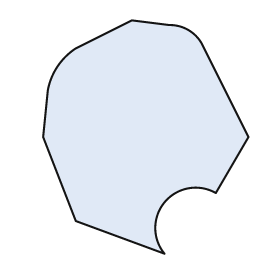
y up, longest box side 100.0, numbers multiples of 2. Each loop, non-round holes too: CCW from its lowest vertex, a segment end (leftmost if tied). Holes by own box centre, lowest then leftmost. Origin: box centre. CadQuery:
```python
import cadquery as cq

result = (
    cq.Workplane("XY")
    .moveTo(8.0, -50.0)
    .threePointArc((8.0, -28.0), (30.0, -24.0))
    .lineTo(44.0, 0.0)
    .lineTo(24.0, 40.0)
    .threePointArc((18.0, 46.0), (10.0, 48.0))
    .lineTo(-6.0, 50.0)
    .lineTo(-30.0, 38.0)
    .threePointArc((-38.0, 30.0), (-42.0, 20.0))
    .lineTo(-44.0, 0.0)
    .lineTo(-30.0, -36.0)
    .close()
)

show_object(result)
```